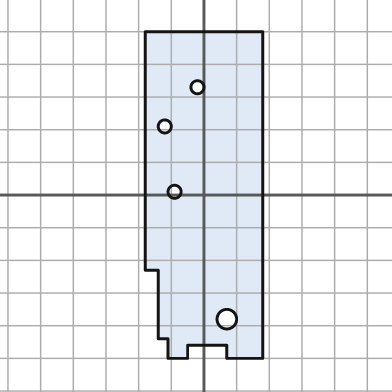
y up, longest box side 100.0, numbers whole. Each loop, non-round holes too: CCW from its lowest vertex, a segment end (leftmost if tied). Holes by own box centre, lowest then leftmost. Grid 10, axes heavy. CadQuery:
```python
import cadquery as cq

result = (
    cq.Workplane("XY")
    .moveTo(-11.0, -50.0)
    .lineTo(-5.0, -50.0)
    .lineTo(-5.0, -46.0)
    .lineTo(7.0, -46.0)
    .lineTo(7.0, -50.0)
    .lineTo(18.0, -50.0)
    .lineTo(18.0, 50.0)
    .lineTo(-18.0, 50.0)
    .lineTo(-18.0, -23.0)
    .lineTo(-14.0, -23.0)
    .lineTo(-14.0, -44.0)
    .lineTo(-11.0, -44.0)
    .close()
    .moveTo(7.0, -38.0)
    .circle(3.0)
    .moveTo(-9.0, 1.0)
    .circle(2.0)
    .moveTo(-12.0, 21.0)
    .circle(2.0)
    .moveTo(-2.0, 33.0)
    .circle(2.0)
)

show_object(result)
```